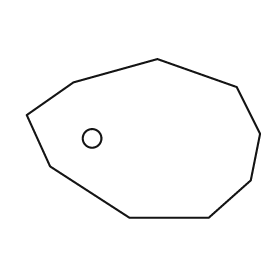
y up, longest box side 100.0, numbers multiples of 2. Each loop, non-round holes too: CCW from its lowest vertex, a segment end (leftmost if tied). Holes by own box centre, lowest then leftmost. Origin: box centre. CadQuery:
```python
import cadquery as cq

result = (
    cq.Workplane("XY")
    .moveTo(-6.0, -34.0)
    .lineTo(28.0, -34.0)
    .lineTo(46.0, -18.0)
    .lineTo(50.0, 2.0)
    .lineTo(40.0, 22.0)
    .lineTo(6.0, 34.0)
    .lineTo(-30.0, 24.0)
    .lineTo(-50.0, 10.0)
    .lineTo(-40.0, -12.0)
    .close()
    .moveTo(-22.0, 0.0)
    .circle(4.0)
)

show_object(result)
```